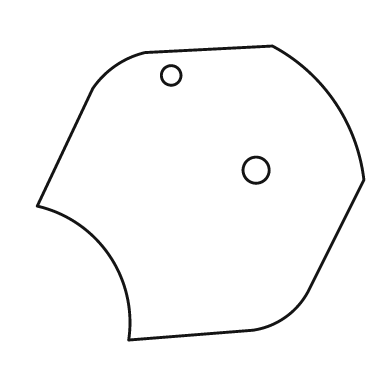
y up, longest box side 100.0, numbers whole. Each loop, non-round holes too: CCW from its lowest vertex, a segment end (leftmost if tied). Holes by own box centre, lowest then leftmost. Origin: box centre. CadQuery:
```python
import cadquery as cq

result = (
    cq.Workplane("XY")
    .moveTo(-22.0, -45.0)
    .lineTo(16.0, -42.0)
    .threePointArc((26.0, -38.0), (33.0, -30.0))
    .lineTo(50.0, 4.0)
    .threePointArc((41.0, 28.0), (22.0, 45.0))
    .lineTo(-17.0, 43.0)
    .threePointArc((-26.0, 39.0), (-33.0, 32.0))
    .lineTo(-50.0, -4.0)
    .threePointArc((-28.0, -19.0), (-22.0, -45.0))
    .close()
    .moveTo(17.0, 7.0)
    .circle(4.0)
    .moveTo(-9.0, 36.0)
    .circle(3.0)
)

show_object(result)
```